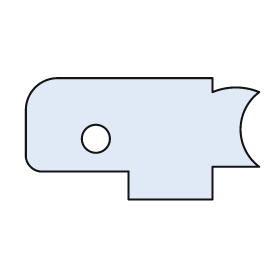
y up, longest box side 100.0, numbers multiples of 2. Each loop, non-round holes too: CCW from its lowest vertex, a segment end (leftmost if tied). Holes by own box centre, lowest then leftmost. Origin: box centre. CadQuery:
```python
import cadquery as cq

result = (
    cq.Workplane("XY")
    .moveTo(-6.0, -26.0)
    .lineTo(30.0, -26.0)
    .lineTo(30.0, -12.0)
    .lineTo(50.0, -12.0)
    .threePointArc((42.0, 4.0), (50.0, 20.0))
    .threePointArc((40.0, 22.0), (30.0, 20.0))
    .lineTo(30.0, 26.0)
    .lineTo(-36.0, 26.0)
    .threePointArc((-46.0, 22.0), (-50.0, 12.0))
    .lineTo(-50.0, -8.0)
    .threePointArc((-48.0, -12.0), (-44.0, -14.0))
    .lineTo(-6.0, -14.0)
    .close()
    .moveTo(-20.0, 0.0)
    .circle(6.0)
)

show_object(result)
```